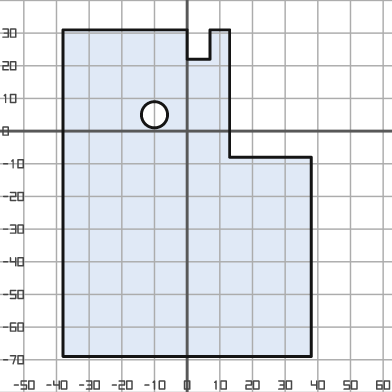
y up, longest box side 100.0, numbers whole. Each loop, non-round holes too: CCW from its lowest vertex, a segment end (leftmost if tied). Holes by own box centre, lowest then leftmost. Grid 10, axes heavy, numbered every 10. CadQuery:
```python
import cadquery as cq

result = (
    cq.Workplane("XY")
    .moveTo(-38.0, -69.0)
    .lineTo(38.0, -69.0)
    .lineTo(38.0, -8.0)
    .lineTo(13.0, -8.0)
    .lineTo(13.0, 31.0)
    .lineTo(7.0, 31.0)
    .lineTo(7.0, 22.0)
    .lineTo(0.0, 22.0)
    .lineTo(0.0, 31.0)
    .lineTo(-38.0, 31.0)
    .close()
    .moveTo(-10.0, 5.0)
    .circle(4.0)
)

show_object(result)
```